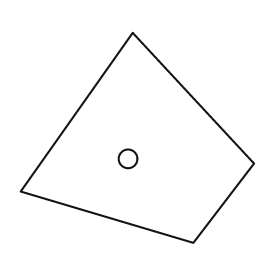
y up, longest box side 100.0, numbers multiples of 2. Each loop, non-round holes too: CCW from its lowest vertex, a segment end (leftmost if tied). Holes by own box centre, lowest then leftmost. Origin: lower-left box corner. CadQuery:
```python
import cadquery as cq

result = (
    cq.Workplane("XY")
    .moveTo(74.0, 0.0)
    .lineTo(100.0, 34.0)
    .lineTo(48.0, 90.0)
    .lineTo(0.0, 22.0)
    .close()
    .moveTo(46.0, 36.0)
    .circle(4.0)
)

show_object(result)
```